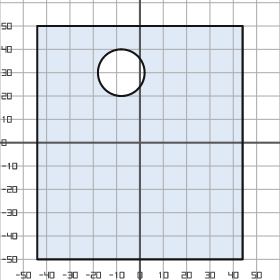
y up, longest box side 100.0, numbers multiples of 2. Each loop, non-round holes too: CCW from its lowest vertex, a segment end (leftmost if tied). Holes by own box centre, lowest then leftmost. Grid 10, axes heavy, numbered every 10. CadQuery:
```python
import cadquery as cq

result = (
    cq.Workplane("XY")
    .moveTo(-44.0, -50.0)
    .lineTo(44.0, -50.0)
    .lineTo(44.0, 50.0)
    .lineTo(-44.0, 50.0)
    .close()
    .moveTo(-8.0, 30.0)
    .circle(10.0)
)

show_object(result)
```